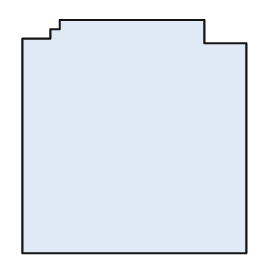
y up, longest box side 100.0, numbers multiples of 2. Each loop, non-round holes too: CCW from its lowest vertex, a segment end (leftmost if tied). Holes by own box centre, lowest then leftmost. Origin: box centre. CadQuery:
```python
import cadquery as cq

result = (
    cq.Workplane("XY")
    .moveTo(-48.0, -50.0)
    .lineTo(48.0, -50.0)
    .lineTo(48.0, 40.0)
    .lineTo(30.0, 40.0)
    .lineTo(30.0, 50.0)
    .lineTo(-32.0, 50.0)
    .lineTo(-32.0, 46.0)
    .lineTo(-36.0, 46.0)
    .lineTo(-36.0, 42.0)
    .lineTo(-48.0, 42.0)
    .close()
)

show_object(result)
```